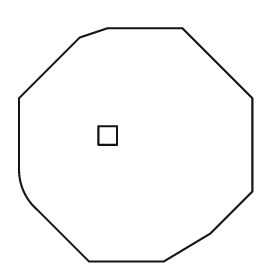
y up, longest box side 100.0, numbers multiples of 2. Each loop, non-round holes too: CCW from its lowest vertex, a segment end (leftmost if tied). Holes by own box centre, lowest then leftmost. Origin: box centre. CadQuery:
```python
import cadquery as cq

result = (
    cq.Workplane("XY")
    .moveTo(-20.0, -50.0)
    .lineTo(12.0, -50.0)
    .lineTo(32.0, -38.0)
    .lineTo(50.0, -20.0)
    .lineTo(50.0, 20.0)
    .lineTo(20.0, 50.0)
    .lineTo(-12.0, 50.0)
    .lineTo(-24.0, 46.0)
    .lineTo(-50.0, 20.0)
    .lineTo(-50.0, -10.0)
    .threePointArc((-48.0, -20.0), (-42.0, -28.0))
    .close()
    .moveTo(-16.0, 0.0)
    .lineTo(-8.0, 0.0)
    .lineTo(-8.0, 8.0)
    .lineTo(-16.0, 8.0)
    .close()
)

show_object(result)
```